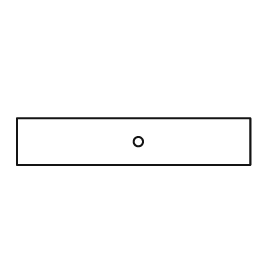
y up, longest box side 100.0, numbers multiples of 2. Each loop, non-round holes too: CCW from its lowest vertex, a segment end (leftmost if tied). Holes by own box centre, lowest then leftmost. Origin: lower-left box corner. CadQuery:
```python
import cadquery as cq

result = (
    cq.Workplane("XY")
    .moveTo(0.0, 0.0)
    .lineTo(100.0, 0.0)
    .lineTo(100.0, 20.0)
    .lineTo(0.0, 20.0)
    .close()
    .moveTo(52.0, 10.0)
    .circle(2.0)
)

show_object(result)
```